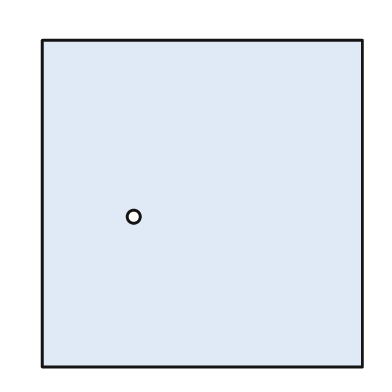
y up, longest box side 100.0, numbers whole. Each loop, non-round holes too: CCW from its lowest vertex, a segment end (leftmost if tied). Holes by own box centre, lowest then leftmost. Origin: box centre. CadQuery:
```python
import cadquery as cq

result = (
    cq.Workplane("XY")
    .moveTo(-49.0, -50.0)
    .lineTo(49.0, -50.0)
    .lineTo(49.0, 50.0)
    .lineTo(-49.0, 50.0)
    .close()
    .moveTo(-21.0, -4.0)
    .circle(2.0)
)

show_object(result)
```